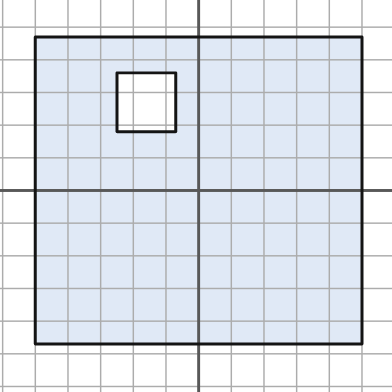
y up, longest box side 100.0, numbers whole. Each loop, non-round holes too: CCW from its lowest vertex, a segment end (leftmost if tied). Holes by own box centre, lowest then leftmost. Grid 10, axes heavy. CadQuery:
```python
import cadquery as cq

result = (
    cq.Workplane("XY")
    .moveTo(-50.0, -47.0)
    .lineTo(50.0, -47.0)
    .lineTo(50.0, 47.0)
    .lineTo(-50.0, 47.0)
    .close()
    .moveTo(-25.0, 18.0)
    .lineTo(-7.0, 18.0)
    .lineTo(-7.0, 36.0)
    .lineTo(-25.0, 36.0)
    .close()
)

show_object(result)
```